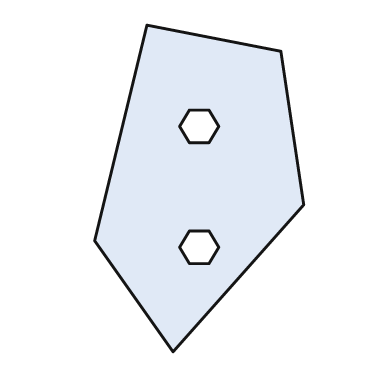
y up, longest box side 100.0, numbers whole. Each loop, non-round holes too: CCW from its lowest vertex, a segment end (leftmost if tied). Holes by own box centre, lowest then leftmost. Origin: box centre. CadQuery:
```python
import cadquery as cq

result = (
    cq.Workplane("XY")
    .moveTo(-8.0, -50.0)
    .lineTo(32.0, -5.0)
    .lineTo(25.0, 42.0)
    .lineTo(-16.0, 50.0)
    .lineTo(-32.0, -16.0)
    .close()
    .moveTo(-3.0, -23.0)
    .lineTo(3.0, -23.0)
    .lineTo(6.0, -18.0)
    .lineTo(3.0, -13.0)
    .lineTo(-3.0, -13.0)
    .lineTo(-6.0, -18.0)
    .close()
    .moveTo(-3.0, 14.0)
    .lineTo(3.0, 14.0)
    .lineTo(6.0, 19.0)
    .lineTo(3.0, 24.0)
    .lineTo(-3.0, 24.0)
    .lineTo(-6.0, 19.0)
    .close()
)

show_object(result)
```